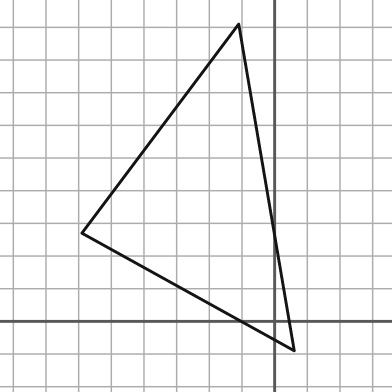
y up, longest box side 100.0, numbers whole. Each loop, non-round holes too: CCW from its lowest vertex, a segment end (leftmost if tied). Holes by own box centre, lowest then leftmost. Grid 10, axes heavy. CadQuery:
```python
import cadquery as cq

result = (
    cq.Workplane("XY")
    .moveTo(6.0, -9.0)
    .lineTo(-11.0, 91.0)
    .lineTo(-59.0, 27.0)
    .close()
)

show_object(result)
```